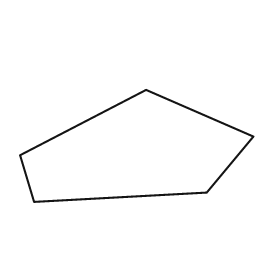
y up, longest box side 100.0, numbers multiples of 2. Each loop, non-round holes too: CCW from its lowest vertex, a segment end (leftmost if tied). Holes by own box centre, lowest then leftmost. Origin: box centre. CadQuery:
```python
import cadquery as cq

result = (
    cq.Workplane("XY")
    .moveTo(-44.0, -24.0)
    .lineTo(30.0, -20.0)
    .lineTo(50.0, 4.0)
    .lineTo(4.0, 24.0)
    .lineTo(-50.0, -4.0)
    .close()
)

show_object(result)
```